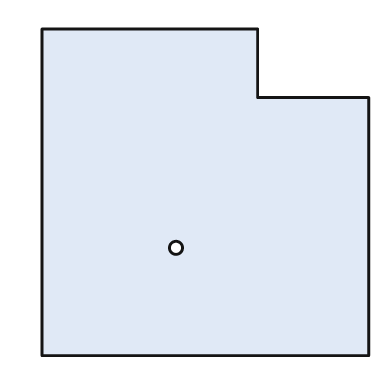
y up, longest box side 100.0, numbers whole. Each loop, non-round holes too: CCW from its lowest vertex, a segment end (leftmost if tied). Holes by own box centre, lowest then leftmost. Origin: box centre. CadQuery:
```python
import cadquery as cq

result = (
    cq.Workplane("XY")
    .moveTo(-50.0, -50.0)
    .lineTo(50.0, -50.0)
    .lineTo(50.0, 29.0)
    .lineTo(16.0, 29.0)
    .lineTo(16.0, 50.0)
    .lineTo(-50.0, 50.0)
    .close()
    .moveTo(-9.0, -17.0)
    .circle(2.0)
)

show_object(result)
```